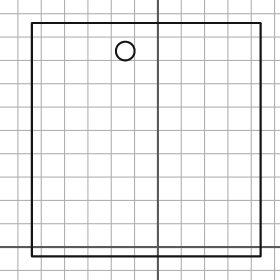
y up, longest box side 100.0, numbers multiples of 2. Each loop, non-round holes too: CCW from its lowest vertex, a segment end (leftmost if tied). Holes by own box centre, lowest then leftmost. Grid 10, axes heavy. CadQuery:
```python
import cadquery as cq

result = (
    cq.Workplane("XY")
    .moveTo(-54.0, -4.0)
    .lineTo(44.0, -4.0)
    .lineTo(44.0, 96.0)
    .lineTo(-54.0, 96.0)
    .close()
    .moveTo(-14.0, 84.0)
    .circle(4.0)
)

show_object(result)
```